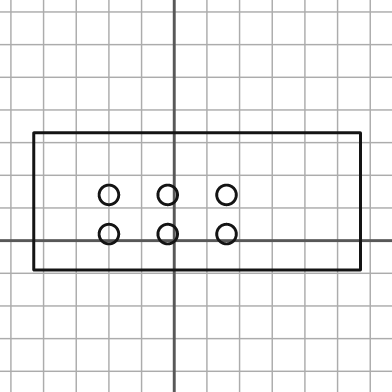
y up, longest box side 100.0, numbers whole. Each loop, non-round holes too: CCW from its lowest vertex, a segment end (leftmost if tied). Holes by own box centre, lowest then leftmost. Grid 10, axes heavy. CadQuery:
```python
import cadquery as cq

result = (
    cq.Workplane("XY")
    .moveTo(-43.0, -9.0)
    .lineTo(57.0, -9.0)
    .lineTo(57.0, 33.0)
    .lineTo(-43.0, 33.0)
    .close()
    .moveTo(-20.0, 2.0)
    .circle(3.0)
    .moveTo(-2.0, 2.0)
    .circle(3.0)
    .moveTo(16.0, 2.0)
    .circle(3.0)
    .moveTo(-20.0, 14.0)
    .circle(3.0)
    .moveTo(-2.0, 14.0)
    .circle(3.0)
    .moveTo(16.0, 14.0)
    .circle(3.0)
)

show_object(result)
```